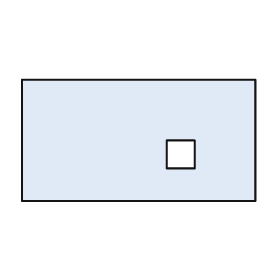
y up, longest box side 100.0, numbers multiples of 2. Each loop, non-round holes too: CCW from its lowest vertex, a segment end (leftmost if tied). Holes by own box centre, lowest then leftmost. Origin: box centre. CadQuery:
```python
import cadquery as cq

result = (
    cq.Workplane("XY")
    .moveTo(-50.0, -26.0)
    .lineTo(50.0, -26.0)
    .lineTo(50.0, 26.0)
    .lineTo(-50.0, 26.0)
    .close()
    .moveTo(12.0, -12.0)
    .lineTo(24.0, -12.0)
    .lineTo(24.0, 0.0)
    .lineTo(12.0, 0.0)
    .close()
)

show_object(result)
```